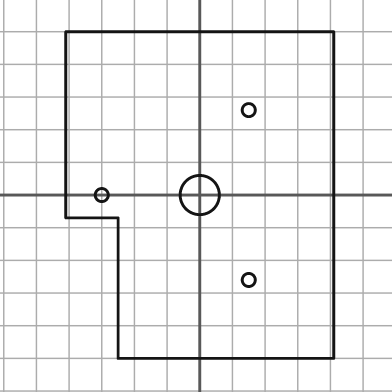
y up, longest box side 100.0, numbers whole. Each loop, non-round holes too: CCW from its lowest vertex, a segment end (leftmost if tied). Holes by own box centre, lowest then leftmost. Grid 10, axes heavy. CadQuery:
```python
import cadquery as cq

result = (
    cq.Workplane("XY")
    .moveTo(-25.0, -50.0)
    .lineTo(41.0, -50.0)
    .lineTo(41.0, 50.0)
    .lineTo(-41.0, 50.0)
    .lineTo(-41.0, -7.0)
    .lineTo(-25.0, -7.0)
    .close()
    .moveTo(15.0, -26.0)
    .circle(2.0)
    .moveTo(-30.0, 0.0)
    .circle(2.0)
    .moveTo(0.0, 0.0)
    .circle(6.0)
    .moveTo(15.0, 26.0)
    .circle(2.0)
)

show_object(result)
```